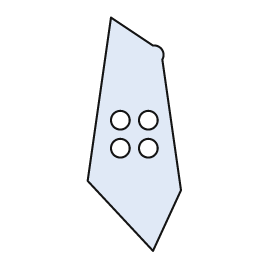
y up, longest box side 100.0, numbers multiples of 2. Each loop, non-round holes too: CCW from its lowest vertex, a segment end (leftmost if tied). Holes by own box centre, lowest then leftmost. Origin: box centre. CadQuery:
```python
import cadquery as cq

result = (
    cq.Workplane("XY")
    .moveTo(8.0, -50.0)
    .lineTo(20.0, -24.0)
    .lineTo(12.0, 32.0)
    .threePointArc((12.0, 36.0), (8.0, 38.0))
    .lineTo(-10.0, 50.0)
    .lineTo(-20.0, -20.0)
    .close()
    .moveTo(-6.0, -6.0)
    .circle(4.0)
    .moveTo(6.0, -6.0)
    .circle(4.0)
    .moveTo(-6.0, 6.0)
    .circle(4.0)
    .moveTo(6.0, 6.0)
    .circle(4.0)
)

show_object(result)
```